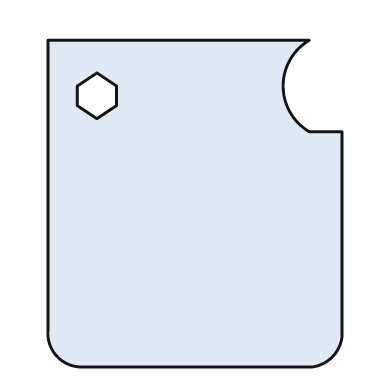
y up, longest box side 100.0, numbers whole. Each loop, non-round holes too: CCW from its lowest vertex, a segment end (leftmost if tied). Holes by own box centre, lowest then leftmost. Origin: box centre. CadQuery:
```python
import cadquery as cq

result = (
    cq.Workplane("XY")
    .moveTo(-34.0, -50.0)
    .lineTo(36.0, -50.0)
    .threePointArc((42.0, -47.0), (45.0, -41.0))
    .lineTo(45.0, 22.0)
    .lineTo(35.0, 22.0)
    .threePointArc((27.0, 36.0), (35.0, 50.0))
    .lineTo(-45.0, 50.0)
    .lineTo(-45.0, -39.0)
    .threePointArc((-42.0, -47.0), (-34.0, -50.0))
    .close()
    .moveTo(-30.0, 26.0)
    .lineTo(-24.0, 30.0)
    .lineTo(-24.0, 36.0)
    .lineTo(-30.0, 40.0)
    .lineTo(-36.0, 36.0)
    .lineTo(-36.0, 30.0)
    .close()
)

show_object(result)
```